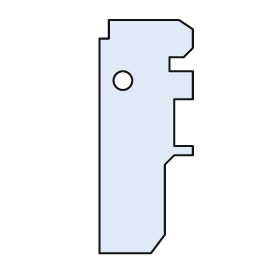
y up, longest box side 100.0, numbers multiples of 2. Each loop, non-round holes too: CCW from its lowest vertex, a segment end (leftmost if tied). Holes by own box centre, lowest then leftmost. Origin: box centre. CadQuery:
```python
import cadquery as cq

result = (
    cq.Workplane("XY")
    .moveTo(-20.0, -50.0)
    .lineTo(2.0, -50.0)
    .lineTo(8.0, -42.0)
    .lineTo(8.0, -12.0)
    .lineTo(12.0, -8.0)
    .lineTo(20.0, -8.0)
    .lineTo(20.0, -4.0)
    .lineTo(12.0, -4.0)
    .lineTo(12.0, 16.0)
    .lineTo(20.0, 16.0)
    .lineTo(20.0, 28.0)
    .lineTo(10.0, 28.0)
    .lineTo(10.0, 34.0)
    .lineTo(16.0, 34.0)
    .lineTo(20.0, 38.0)
    .lineTo(20.0, 46.0)
    .lineTo(14.0, 50.0)
    .lineTo(-16.0, 50.0)
    .lineTo(-16.0, 42.0)
    .lineTo(-20.0, 42.0)
    .close()
    .moveTo(-10.0, 24.0)
    .circle(4.0)
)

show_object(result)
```